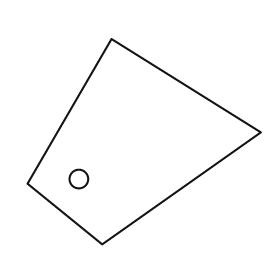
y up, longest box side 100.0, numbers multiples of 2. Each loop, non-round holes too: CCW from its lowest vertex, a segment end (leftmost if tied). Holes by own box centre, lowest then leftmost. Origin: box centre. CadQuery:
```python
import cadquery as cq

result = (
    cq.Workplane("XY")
    .moveTo(-18.0, -44.0)
    .lineTo(50.0, 4.0)
    .lineTo(-14.0, 44.0)
    .lineTo(-50.0, -18.0)
    .close()
    .moveTo(-28.0, -16.0)
    .circle(4.0)
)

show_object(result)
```